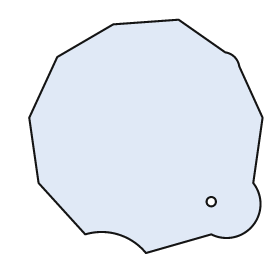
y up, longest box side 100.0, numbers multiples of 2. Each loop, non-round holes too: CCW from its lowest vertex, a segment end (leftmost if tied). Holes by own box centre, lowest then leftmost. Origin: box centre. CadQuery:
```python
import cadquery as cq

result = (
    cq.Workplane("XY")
    .moveTo(0.0, -50.0)
    .lineTo(28.0, -42.0)
    .threePointArc((46.0, -38.0), (46.0, -20.0))
    .lineTo(50.0, 8.0)
    .lineTo(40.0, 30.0)
    .threePointArc((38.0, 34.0), (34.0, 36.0))
    .lineTo(14.0, 50.0)
    .lineTo(-14.0, 48.0)
    .lineTo(-38.0, 34.0)
    .lineTo(-50.0, 8.0)
    .lineTo(-46.0, -20.0)
    .lineTo(-26.0, -42.0)
    .threePointArc((-12.0, -42.0), (0.0, -50.0))
    .close()
    .moveTo(28.0, -28.0)
    .circle(2.0)
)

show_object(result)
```